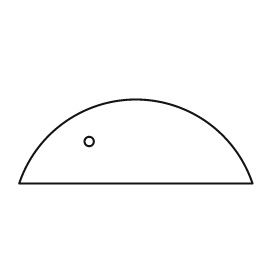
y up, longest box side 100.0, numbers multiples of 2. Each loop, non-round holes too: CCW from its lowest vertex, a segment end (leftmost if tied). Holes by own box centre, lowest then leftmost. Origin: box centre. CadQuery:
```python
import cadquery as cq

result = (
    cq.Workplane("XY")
    .moveTo(-50.0, -18.0)
    .lineTo(50.0, -18.0)
    .threePointArc((0.0, 18.0), (-50.0, -18.0))
    .close()
    .moveTo(-20.0, 0.0)
    .circle(2.0)
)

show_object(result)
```